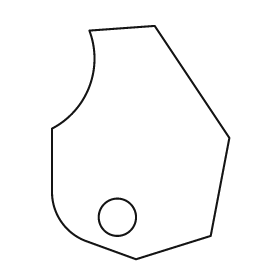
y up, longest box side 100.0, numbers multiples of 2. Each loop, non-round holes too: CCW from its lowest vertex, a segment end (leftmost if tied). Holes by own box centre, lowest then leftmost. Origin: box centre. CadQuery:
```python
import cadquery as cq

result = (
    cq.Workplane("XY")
    .moveTo(-2.0, -50.0)
    .lineTo(30.0, -40.0)
    .lineTo(38.0, 2.0)
    .lineTo(6.0, 50.0)
    .lineTo(-22.0, 48.0)
    .threePointArc((-22.0, 24.0), (-38.0, 6.0))
    .lineTo(-38.0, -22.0)
    .threePointArc((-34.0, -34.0), (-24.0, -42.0))
    .close()
    .moveTo(-10.0, -32.0)
    .circle(8.0)
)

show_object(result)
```